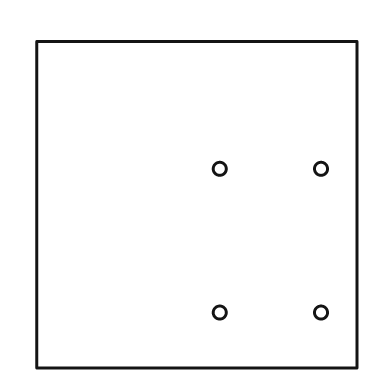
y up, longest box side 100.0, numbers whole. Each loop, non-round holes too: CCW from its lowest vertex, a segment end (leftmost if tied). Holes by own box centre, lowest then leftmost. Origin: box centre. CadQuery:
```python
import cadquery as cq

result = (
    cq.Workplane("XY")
    .moveTo(-49.0, -50.0)
    .lineTo(49.0, -50.0)
    .lineTo(49.0, 50.0)
    .lineTo(-49.0, 50.0)
    .close()
    .moveTo(7.0, -33.0)
    .circle(2.0)
    .moveTo(38.0, -33.0)
    .circle(2.0)
    .moveTo(7.0, 11.0)
    .circle(2.0)
    .moveTo(38.0, 11.0)
    .circle(2.0)
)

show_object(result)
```